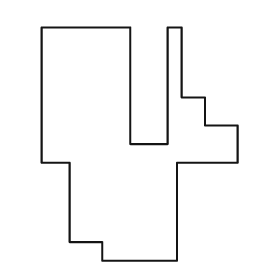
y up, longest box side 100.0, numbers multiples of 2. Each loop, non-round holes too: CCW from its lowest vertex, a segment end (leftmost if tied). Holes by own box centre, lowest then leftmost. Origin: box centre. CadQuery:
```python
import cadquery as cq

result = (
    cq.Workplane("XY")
    .moveTo(-16.0, -50.0)
    .lineTo(16.0, -50.0)
    .lineTo(16.0, -8.0)
    .lineTo(42.0, -8.0)
    .lineTo(42.0, 8.0)
    .lineTo(28.0, 8.0)
    .lineTo(28.0, 20.0)
    .lineTo(18.0, 20.0)
    .lineTo(18.0, 50.0)
    .lineTo(12.0, 50.0)
    .lineTo(12.0, 0.0)
    .lineTo(-4.0, 0.0)
    .lineTo(-4.0, 50.0)
    .lineTo(-42.0, 50.0)
    .lineTo(-42.0, -8.0)
    .lineTo(-30.0, -8.0)
    .lineTo(-30.0, -42.0)
    .lineTo(-16.0, -42.0)
    .close()
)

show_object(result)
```